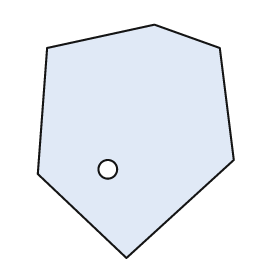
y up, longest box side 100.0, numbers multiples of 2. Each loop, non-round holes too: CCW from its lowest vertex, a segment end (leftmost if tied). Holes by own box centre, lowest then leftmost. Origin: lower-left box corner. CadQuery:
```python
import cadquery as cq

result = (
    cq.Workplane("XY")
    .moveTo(38.0, 0.0)
    .lineTo(84.0, 42.0)
    .lineTo(78.0, 90.0)
    .lineTo(50.0, 100.0)
    .lineTo(4.0, 90.0)
    .lineTo(0.0, 36.0)
    .close()
    .moveTo(30.0, 38.0)
    .circle(4.0)
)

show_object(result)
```